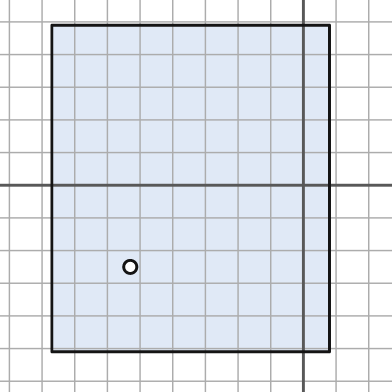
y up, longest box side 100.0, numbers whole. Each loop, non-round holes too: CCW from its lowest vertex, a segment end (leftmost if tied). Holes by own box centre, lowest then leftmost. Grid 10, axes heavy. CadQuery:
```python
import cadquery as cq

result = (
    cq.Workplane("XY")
    .moveTo(-77.0, -51.0)
    .lineTo(8.0, -51.0)
    .lineTo(8.0, 49.0)
    .lineTo(-77.0, 49.0)
    .close()
    .moveTo(-53.0, -25.0)
    .circle(2.0)
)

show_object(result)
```